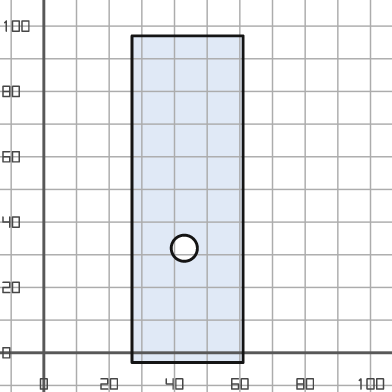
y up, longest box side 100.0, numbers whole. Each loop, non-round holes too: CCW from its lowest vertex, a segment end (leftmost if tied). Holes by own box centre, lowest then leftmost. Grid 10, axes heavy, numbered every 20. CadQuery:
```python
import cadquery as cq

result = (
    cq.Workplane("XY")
    .moveTo(27.0, -3.0)
    .lineTo(61.0, -3.0)
    .lineTo(61.0, 97.0)
    .lineTo(27.0, 97.0)
    .close()
    .moveTo(43.0, 32.0)
    .circle(4.0)
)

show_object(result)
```